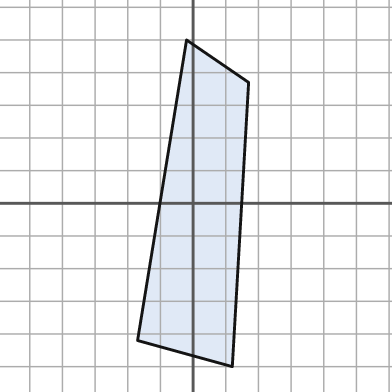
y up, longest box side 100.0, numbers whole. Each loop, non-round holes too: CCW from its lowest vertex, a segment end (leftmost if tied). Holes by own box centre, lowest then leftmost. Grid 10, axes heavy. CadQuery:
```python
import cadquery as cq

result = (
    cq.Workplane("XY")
    .moveTo(12.0, -50.0)
    .lineTo(17.0, 37.0)
    .lineTo(-2.0, 50.0)
    .lineTo(-17.0, -42.0)
    .close()
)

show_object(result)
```